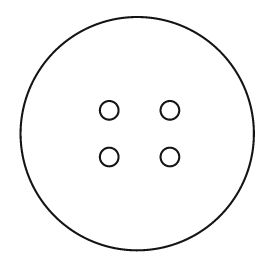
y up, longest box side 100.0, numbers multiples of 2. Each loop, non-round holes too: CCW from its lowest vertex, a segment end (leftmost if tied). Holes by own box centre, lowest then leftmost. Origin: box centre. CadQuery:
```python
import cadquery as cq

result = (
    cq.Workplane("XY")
    .moveTo(0.0, 0.0)
    .circle(50.0)
    .moveTo(-12.0, -10.0)
    .circle(4.0)
    .moveTo(14.0, -10.0)
    .circle(4.0)
    .moveTo(-12.0, 10.0)
    .circle(4.0)
    .moveTo(14.0, 10.0)
    .circle(4.0)
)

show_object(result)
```